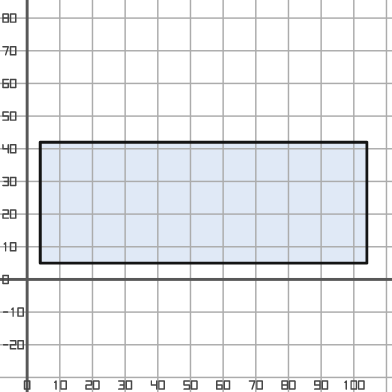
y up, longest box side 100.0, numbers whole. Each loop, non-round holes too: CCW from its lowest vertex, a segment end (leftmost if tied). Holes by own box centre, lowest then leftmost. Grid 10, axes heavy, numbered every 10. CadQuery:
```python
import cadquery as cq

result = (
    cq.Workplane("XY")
    .moveTo(4.0, 5.0)
    .lineTo(104.0, 5.0)
    .lineTo(104.0, 42.0)
    .lineTo(4.0, 42.0)
    .close()
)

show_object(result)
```